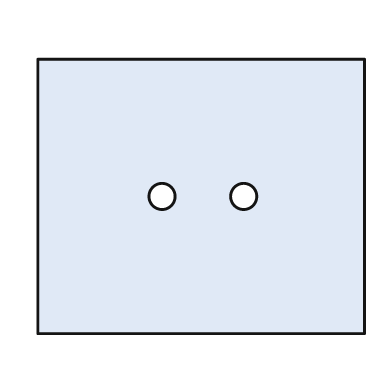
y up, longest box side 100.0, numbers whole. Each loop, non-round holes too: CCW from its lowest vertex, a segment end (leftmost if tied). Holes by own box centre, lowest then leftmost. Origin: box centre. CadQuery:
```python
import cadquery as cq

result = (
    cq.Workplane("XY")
    .moveTo(-50.0, -42.0)
    .lineTo(50.0, -42.0)
    .lineTo(50.0, 42.0)
    .lineTo(-50.0, 42.0)
    .close()
    .moveTo(-12.0, 0.0)
    .circle(4.0)
    .moveTo(13.0, 0.0)
    .circle(4.0)
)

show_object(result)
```